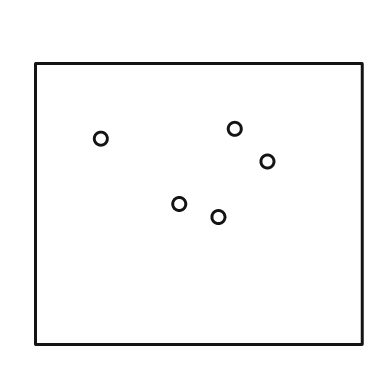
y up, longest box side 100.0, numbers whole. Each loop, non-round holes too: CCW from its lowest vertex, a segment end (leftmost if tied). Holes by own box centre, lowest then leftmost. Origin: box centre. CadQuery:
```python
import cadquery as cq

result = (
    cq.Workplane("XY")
    .moveTo(-50.0, -43.0)
    .lineTo(50.0, -43.0)
    .lineTo(50.0, 43.0)
    .lineTo(-50.0, 43.0)
    .close()
    .moveTo(6.0, -4.0)
    .circle(2.0)
    .moveTo(-6.0, 0.0)
    .circle(2.0)
    .moveTo(21.0, 13.0)
    .circle(2.0)
    .moveTo(-30.0, 20.0)
    .circle(2.0)
    .moveTo(11.0, 23.0)
    .circle(2.0)
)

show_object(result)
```